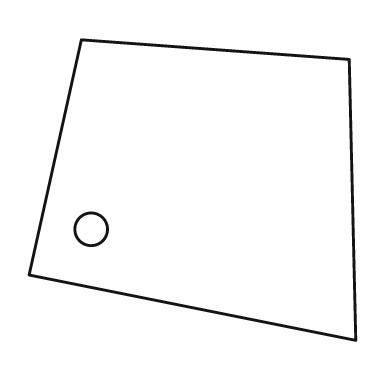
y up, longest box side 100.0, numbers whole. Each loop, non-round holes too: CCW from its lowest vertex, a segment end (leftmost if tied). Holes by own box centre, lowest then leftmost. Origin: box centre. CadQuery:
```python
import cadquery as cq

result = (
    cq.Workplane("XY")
    .moveTo(50.0, -46.0)
    .lineTo(48.0, 40.0)
    .lineTo(-34.0, 46.0)
    .lineTo(-50.0, -26.0)
    .close()
    .moveTo(-31.0, -12.0)
    .circle(5.0)
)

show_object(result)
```